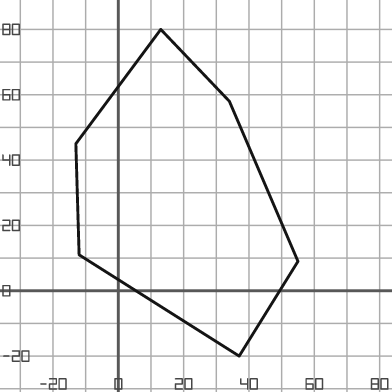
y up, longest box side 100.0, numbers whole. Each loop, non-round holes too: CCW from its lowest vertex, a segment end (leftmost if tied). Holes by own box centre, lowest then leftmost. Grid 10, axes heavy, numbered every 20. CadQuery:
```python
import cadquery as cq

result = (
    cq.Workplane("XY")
    .moveTo(37.0, -20.0)
    .lineTo(55.0, 9.0)
    .lineTo(34.0, 58.0)
    .lineTo(13.0, 80.0)
    .lineTo(-13.0, 45.0)
    .lineTo(-12.0, 11.0)
    .close()
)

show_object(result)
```